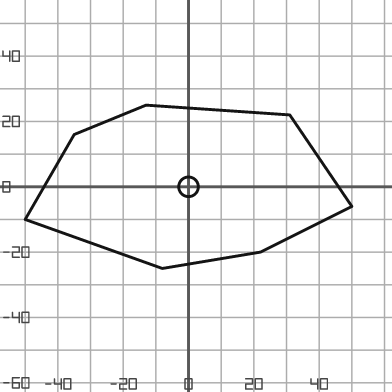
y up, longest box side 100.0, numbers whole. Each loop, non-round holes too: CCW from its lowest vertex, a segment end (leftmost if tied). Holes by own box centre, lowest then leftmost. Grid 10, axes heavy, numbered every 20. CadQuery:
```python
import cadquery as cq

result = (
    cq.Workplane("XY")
    .moveTo(-8.0, -25.0)
    .lineTo(22.0, -20.0)
    .lineTo(50.0, -6.0)
    .lineTo(31.0, 22.0)
    .lineTo(-13.0, 25.0)
    .lineTo(-35.0, 16.0)
    .lineTo(-50.0, -10.0)
    .close()
    .moveTo(0.0, 0.0)
    .circle(3.0)
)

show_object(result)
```